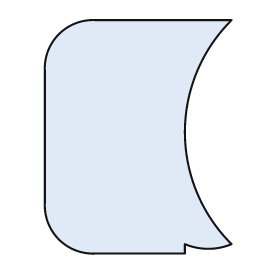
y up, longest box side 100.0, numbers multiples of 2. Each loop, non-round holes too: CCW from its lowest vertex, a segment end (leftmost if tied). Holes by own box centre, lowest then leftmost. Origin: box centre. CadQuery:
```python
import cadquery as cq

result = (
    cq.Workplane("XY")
    .moveTo(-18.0, -50.0)
    .lineTo(20.0, -50.0)
    .lineTo(20.0, -46.0)
    .threePointArc((30.0, -48.0), (40.0, -46.0))
    .threePointArc((20.0, 2.0), (40.0, 50.0))
    .lineTo(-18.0, 50.0)
    .threePointArc((-34.0, 44.0), (-40.0, 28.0))
    .lineTo(-40.0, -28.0)
    .threePointArc((-34.0, -44.0), (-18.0, -50.0))
    .close()
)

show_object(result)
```